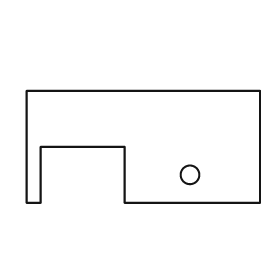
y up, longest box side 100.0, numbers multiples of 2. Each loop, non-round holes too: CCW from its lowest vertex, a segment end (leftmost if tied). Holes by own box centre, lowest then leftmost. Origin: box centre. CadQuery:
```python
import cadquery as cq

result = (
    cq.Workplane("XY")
    .moveTo(-50.0, -24.0)
    .lineTo(-44.0, -24.0)
    .lineTo(-44.0, 0.0)
    .lineTo(-8.0, 0.0)
    .lineTo(-8.0, -24.0)
    .lineTo(50.0, -24.0)
    .lineTo(50.0, 24.0)
    .lineTo(-50.0, 24.0)
    .close()
    .moveTo(20.0, -12.0)
    .circle(4.0)
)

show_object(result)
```